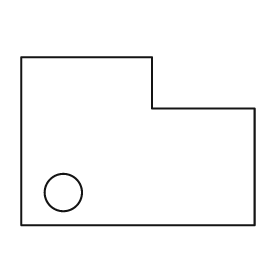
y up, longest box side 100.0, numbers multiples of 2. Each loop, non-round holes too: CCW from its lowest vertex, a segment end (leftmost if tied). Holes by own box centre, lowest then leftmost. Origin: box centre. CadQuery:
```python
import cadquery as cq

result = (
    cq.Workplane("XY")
    .moveTo(-50.0, -36.0)
    .lineTo(50.0, -36.0)
    .lineTo(50.0, 14.0)
    .lineTo(6.0, 14.0)
    .lineTo(6.0, 36.0)
    .lineTo(-50.0, 36.0)
    .close()
    .moveTo(-32.0, -22.0)
    .circle(8.0)
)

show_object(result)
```